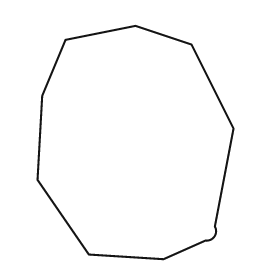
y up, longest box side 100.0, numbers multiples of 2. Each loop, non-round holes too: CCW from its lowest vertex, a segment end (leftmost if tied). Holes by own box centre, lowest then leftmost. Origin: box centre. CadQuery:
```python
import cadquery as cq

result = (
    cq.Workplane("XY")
    .moveTo(12.0, -50.0)
    .lineTo(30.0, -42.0)
    .threePointArc((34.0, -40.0), (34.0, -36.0))
    .lineTo(42.0, 6.0)
    .lineTo(24.0, 42.0)
    .lineTo(0.0, 50.0)
    .lineTo(-30.0, 44.0)
    .lineTo(-40.0, 20.0)
    .lineTo(-42.0, -16.0)
    .lineTo(-20.0, -48.0)
    .close()
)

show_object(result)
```